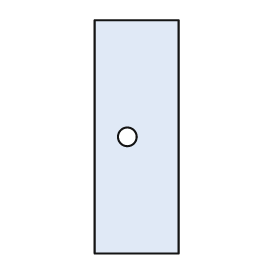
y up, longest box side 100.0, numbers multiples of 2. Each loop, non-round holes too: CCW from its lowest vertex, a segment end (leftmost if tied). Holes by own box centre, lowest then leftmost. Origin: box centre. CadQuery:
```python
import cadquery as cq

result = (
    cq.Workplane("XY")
    .moveTo(-18.0, -50.0)
    .lineTo(18.0, -50.0)
    .lineTo(18.0, 50.0)
    .lineTo(-18.0, 50.0)
    .close()
    .moveTo(-4.0, 0.0)
    .circle(4.0)
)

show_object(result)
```